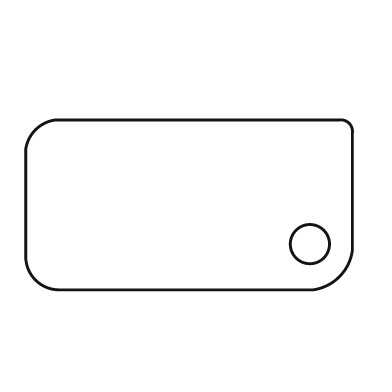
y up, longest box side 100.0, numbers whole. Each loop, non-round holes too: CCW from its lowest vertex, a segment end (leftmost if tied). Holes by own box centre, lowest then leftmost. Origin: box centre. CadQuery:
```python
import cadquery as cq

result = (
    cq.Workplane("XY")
    .moveTo(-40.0, -26.0)
    .lineTo(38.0, -26.0)
    .threePointArc((46.0, -22.0), (50.0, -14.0))
    .lineTo(50.0, 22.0)
    .threePointArc((49.0, 25.0), (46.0, 26.0))
    .lineTo(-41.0, 26.0)
    .threePointArc((-47.0, 23.0), (-50.0, 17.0))
    .lineTo(-50.0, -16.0)
    .threePointArc((-47.0, -23.0), (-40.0, -26.0))
    .close()
    .moveTo(37.0, -12.0)
    .circle(6.0)
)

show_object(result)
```